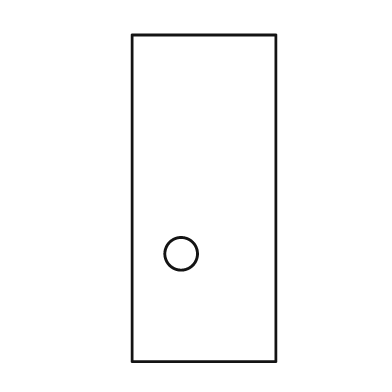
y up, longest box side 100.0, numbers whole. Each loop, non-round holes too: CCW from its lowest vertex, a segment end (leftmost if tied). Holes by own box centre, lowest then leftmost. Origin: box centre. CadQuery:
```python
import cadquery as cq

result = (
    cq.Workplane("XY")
    .moveTo(-22.0, -50.0)
    .lineTo(22.0, -50.0)
    .lineTo(22.0, 50.0)
    .lineTo(-22.0, 50.0)
    .close()
    .moveTo(-7.0, -17.0)
    .circle(5.0)
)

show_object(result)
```